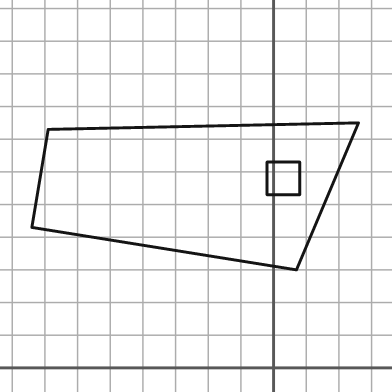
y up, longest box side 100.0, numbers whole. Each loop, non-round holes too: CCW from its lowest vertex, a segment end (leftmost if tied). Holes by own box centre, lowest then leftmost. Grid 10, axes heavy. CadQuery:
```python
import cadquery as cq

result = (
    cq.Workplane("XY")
    .moveTo(7.0, 30.0)
    .lineTo(26.0, 75.0)
    .lineTo(-69.0, 73.0)
    .lineTo(-74.0, 43.0)
    .close()
    .moveTo(-2.0, 53.0)
    .lineTo(8.0, 53.0)
    .lineTo(8.0, 63.0)
    .lineTo(-2.0, 63.0)
    .close()
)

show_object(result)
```